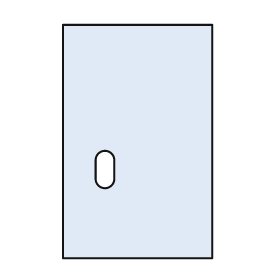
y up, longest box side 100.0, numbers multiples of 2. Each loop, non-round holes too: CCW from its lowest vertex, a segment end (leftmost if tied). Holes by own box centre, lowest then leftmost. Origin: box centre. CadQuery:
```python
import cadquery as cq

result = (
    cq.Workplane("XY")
    .moveTo(-32.0, -50.0)
    .lineTo(32.0, -50.0)
    .lineTo(32.0, 50.0)
    .lineTo(-32.0, 50.0)
    .close()
    .moveTo(-18.0, -16.0)
    .threePointArc((-14.0, -20.0), (-10.0, -16.0))
    .lineTo(-10.0, -8.0)
    .threePointArc((-14.0, -4.0), (-18.0, -8.0))
    .close()
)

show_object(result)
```